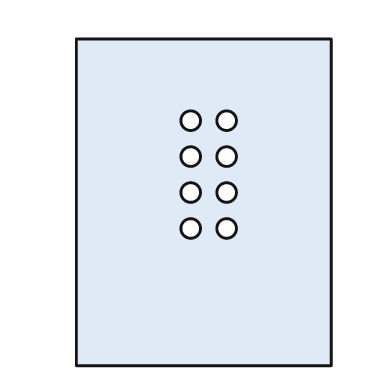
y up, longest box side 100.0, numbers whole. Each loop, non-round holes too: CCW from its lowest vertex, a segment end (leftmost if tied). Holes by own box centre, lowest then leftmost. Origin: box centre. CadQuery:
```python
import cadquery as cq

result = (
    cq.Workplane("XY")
    .moveTo(-39.0, -50.0)
    .lineTo(39.0, -50.0)
    .lineTo(39.0, 50.0)
    .lineTo(-39.0, 50.0)
    .close()
    .moveTo(-4.0, -8.0)
    .circle(3.0)
    .moveTo(7.0, -8.0)
    .circle(3.0)
    .moveTo(-4.0, 3.0)
    .circle(3.0)
    .moveTo(7.0, 3.0)
    .circle(3.0)
    .moveTo(-4.0, 14.0)
    .circle(3.0)
    .moveTo(7.0, 14.0)
    .circle(3.0)
    .moveTo(-4.0, 25.0)
    .circle(3.0)
    .moveTo(7.0, 25.0)
    .circle(3.0)
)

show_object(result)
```